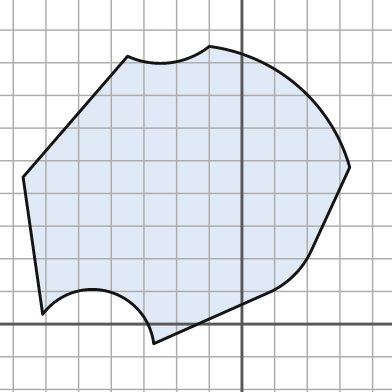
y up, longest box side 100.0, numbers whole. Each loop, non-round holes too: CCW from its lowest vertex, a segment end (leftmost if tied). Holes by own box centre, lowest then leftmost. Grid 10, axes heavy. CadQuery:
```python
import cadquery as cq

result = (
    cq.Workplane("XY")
    .moveTo(-27.0, -6.0)
    .lineTo(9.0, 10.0)
    .threePointArc((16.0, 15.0), (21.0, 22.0))
    .lineTo(33.0, 48.0)
    .threePointArc((17.0, 73.0), (-10.0, 85.0))
    .threePointArc((-22.0, 80.0), (-35.0, 82.0))
    .lineTo(-67.0, 45.0)
    .lineTo(-61.0, 3.0)
    .threePointArc((-41.0, 10.0), (-27.0, -6.0))
    .close()
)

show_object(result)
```